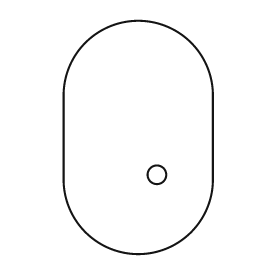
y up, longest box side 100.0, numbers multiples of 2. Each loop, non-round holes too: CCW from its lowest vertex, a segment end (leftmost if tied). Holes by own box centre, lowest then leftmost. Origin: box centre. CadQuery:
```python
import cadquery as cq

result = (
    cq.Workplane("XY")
    .moveTo(-32.0, -18.0)
    .threePointArc((0.0, -50.0), (32.0, -18.0))
    .lineTo(32.0, 18.0)
    .threePointArc((0.0, 50.0), (-32.0, 18.0))
    .close()
    .moveTo(8.0, -16.0)
    .circle(4.0)
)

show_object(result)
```